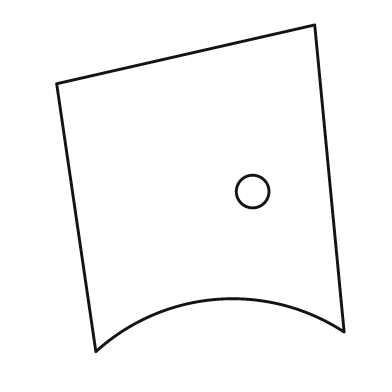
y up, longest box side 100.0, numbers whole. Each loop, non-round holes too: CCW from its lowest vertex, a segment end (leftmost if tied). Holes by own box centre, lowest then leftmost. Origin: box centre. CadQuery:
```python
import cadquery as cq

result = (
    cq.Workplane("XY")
    .moveTo(-32.0, -50.0)
    .threePointArc((5.0, -34.0), (44.0, -44.0))
    .lineTo(35.0, 50.0)
    .lineTo(-44.0, 32.0)
    .close()
    .moveTo(16.0, -1.0)
    .circle(5.0)
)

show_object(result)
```